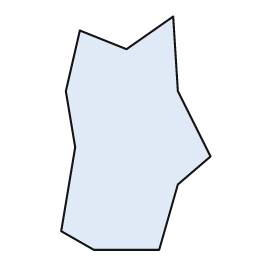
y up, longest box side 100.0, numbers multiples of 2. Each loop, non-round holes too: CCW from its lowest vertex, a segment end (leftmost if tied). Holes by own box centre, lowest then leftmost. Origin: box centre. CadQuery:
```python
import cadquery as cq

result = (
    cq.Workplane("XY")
    .moveTo(-18.0, -50.0)
    .lineTo(10.0, -50.0)
    .lineTo(18.0, -22.0)
    .lineTo(32.0, -10.0)
    .lineTo(18.0, 18.0)
    .lineTo(16.0, 50.0)
    .lineTo(-4.0, 36.0)
    .lineTo(-24.0, 44.0)
    .lineTo(-30.0, 18.0)
    .lineTo(-26.0, -6.0)
    .lineTo(-32.0, -42.0)
    .close()
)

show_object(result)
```